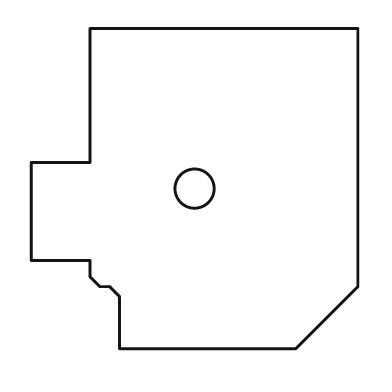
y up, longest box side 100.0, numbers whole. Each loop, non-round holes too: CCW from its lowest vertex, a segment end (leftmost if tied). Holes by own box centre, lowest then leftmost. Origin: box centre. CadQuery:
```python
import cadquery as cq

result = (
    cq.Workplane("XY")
    .moveTo(-23.0, -49.0)
    .lineTo(31.0, -49.0)
    .lineTo(50.0, -30.0)
    .lineTo(50.0, 49.0)
    .lineTo(-32.0, 49.0)
    .lineTo(-32.0, 8.0)
    .lineTo(-50.0, 8.0)
    .lineTo(-50.0, -22.0)
    .lineTo(-32.0, -22.0)
    .lineTo(-32.0, -27.0)
    .lineTo(-29.0, -30.0)
    .lineTo(-26.0, -30.0)
    .lineTo(-23.0, -33.0)
    .close()
    .moveTo(0.0, 0.0)
    .circle(6.0)
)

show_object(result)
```